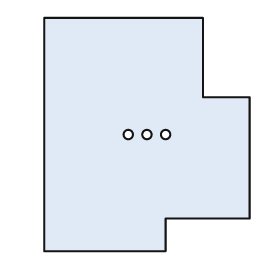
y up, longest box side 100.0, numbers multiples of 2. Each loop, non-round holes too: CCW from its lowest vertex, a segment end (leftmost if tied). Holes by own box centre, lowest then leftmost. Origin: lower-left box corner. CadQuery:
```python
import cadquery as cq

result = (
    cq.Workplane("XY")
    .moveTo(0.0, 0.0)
    .lineTo(52.0, 0.0)
    .lineTo(52.0, 14.0)
    .lineTo(88.0, 14.0)
    .lineTo(88.0, 66.0)
    .lineTo(68.0, 66.0)
    .lineTo(68.0, 100.0)
    .lineTo(0.0, 100.0)
    .close()
    .moveTo(36.0, 50.0)
    .circle(2.0)
    .moveTo(44.0, 50.0)
    .circle(2.0)
    .moveTo(52.0, 50.0)
    .circle(2.0)
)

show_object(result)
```